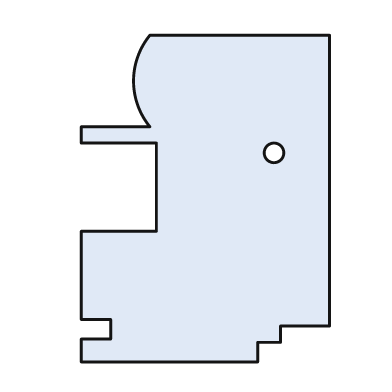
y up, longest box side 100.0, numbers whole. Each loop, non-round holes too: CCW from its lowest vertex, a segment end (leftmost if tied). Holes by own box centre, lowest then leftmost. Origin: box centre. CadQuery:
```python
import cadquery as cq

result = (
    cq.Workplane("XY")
    .moveTo(-38.0, -50.0)
    .lineTo(16.0, -50.0)
    .lineTo(16.0, -44.0)
    .lineTo(23.0, -44.0)
    .lineTo(23.0, -39.0)
    .lineTo(38.0, -39.0)
    .lineTo(38.0, 50.0)
    .lineTo(-17.0, 50.0)
    .threePointArc((-22.0, 36.0), (-17.0, 22.0))
    .lineTo(-38.0, 22.0)
    .lineTo(-38.0, 17.0)
    .lineTo(-15.0, 17.0)
    .lineTo(-15.0, -10.0)
    .lineTo(-38.0, -10.0)
    .lineTo(-38.0, -37.0)
    .lineTo(-29.0, -37.0)
    .lineTo(-29.0, -43.0)
    .lineTo(-38.0, -43.0)
    .close()
    .moveTo(21.0, 14.0)
    .circle(3.0)
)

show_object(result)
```